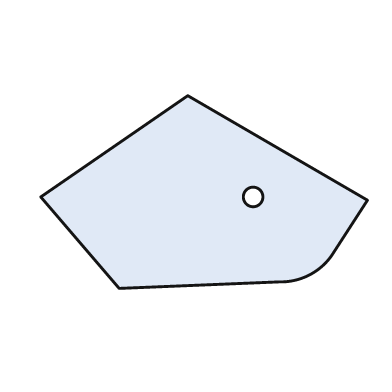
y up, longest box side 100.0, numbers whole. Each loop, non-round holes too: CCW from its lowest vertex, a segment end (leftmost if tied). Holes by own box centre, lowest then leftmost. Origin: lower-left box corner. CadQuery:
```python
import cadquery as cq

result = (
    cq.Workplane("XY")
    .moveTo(24.0, 0.0)
    .lineTo(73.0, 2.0)
    .threePointArc((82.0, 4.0), (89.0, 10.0))
    .lineTo(100.0, 27.0)
    .lineTo(45.0, 59.0)
    .lineTo(0.0, 28.0)
    .close()
    .moveTo(65.0, 28.0)
    .circle(3.0)
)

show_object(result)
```